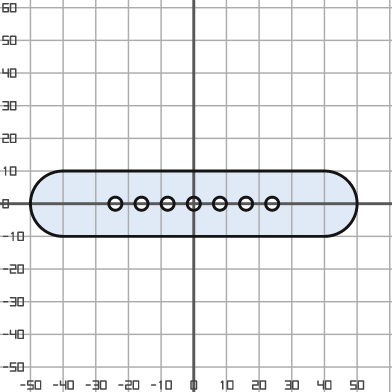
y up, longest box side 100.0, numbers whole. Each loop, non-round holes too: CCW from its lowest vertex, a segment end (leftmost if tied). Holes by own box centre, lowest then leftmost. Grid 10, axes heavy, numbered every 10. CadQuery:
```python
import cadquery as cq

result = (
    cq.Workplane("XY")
    .moveTo(-40.0, -10.0)
    .lineTo(40.0, -10.0)
    .threePointArc((50.0, 0.0), (40.0, 10.0))
    .lineTo(-40.0, 10.0)
    .threePointArc((-50.0, 0.0), (-40.0, -10.0))
    .close()
    .moveTo(-24.0, 0.0)
    .circle(2.0)
    .moveTo(-16.0, 0.0)
    .circle(2.0)
    .moveTo(-8.0, 0.0)
    .circle(2.0)
    .moveTo(0.0, 0.0)
    .circle(2.0)
    .moveTo(8.0, 0.0)
    .circle(2.0)
    .moveTo(16.0, 0.0)
    .circle(2.0)
    .moveTo(24.0, 0.0)
    .circle(2.0)
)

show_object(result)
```